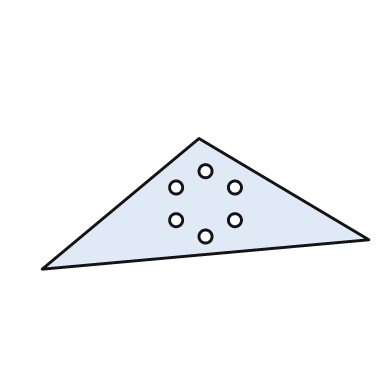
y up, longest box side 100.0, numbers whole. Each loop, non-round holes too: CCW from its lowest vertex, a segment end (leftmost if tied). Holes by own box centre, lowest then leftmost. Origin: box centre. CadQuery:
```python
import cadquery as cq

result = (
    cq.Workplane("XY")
    .moveTo(-50.0, -20.0)
    .lineTo(50.0, -11.0)
    .lineTo(-2.0, 20.0)
    .close()
    .moveTo(0.0, -10.0)
    .circle(2.0)
    .moveTo(-9.0, -5.0)
    .circle(2.0)
    .moveTo(9.0, -5.0)
    .circle(2.0)
    .moveTo(-9.0, 5.0)
    .circle(2.0)
    .moveTo(9.0, 5.0)
    .circle(2.0)
    .moveTo(0.0, 10.0)
    .circle(2.0)
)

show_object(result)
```